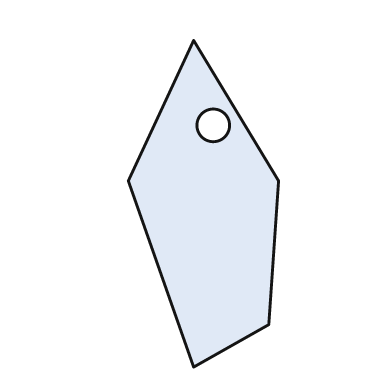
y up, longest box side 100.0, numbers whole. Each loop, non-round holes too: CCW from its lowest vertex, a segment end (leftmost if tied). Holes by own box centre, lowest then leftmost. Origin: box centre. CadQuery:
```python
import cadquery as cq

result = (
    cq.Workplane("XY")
    .moveTo(-3.0, -50.0)
    .lineTo(20.0, -37.0)
    .lineTo(23.0, 7.0)
    .lineTo(-3.0, 50.0)
    .lineTo(-23.0, 7.0)
    .close()
    .moveTo(3.0, 24.0)
    .circle(5.0)
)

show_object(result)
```